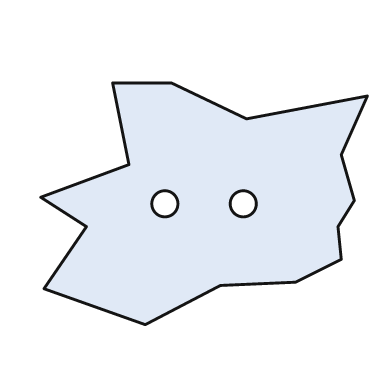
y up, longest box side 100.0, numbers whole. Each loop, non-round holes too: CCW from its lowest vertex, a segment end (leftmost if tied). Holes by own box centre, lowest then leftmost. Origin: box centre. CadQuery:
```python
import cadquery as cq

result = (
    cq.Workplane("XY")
    .moveTo(-18.0, -37.0)
    .lineTo(5.0, -25.0)
    .lineTo(28.0, -24.0)
    .lineTo(42.0, -17.0)
    .lineTo(41.0, -7.0)
    .lineTo(46.0, 1.0)
    .lineTo(42.0, 15.0)
    .lineTo(50.0, 33.0)
    .lineTo(13.0, 26.0)
    .lineTo(-10.0, 37.0)
    .lineTo(-28.0, 37.0)
    .lineTo(-23.0, 12.0)
    .lineTo(-50.0, 2.0)
    .lineTo(-36.0, -7.0)
    .lineTo(-49.0, -26.0)
    .close()
    .moveTo(-12.0, 0.0)
    .circle(4.0)
    .moveTo(12.0, 0.0)
    .circle(4.0)
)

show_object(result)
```